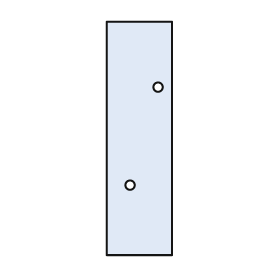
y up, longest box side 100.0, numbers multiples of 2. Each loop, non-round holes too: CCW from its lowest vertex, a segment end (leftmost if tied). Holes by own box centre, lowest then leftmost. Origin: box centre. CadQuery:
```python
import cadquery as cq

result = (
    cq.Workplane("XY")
    .moveTo(-14.0, -50.0)
    .lineTo(14.0, -50.0)
    .lineTo(14.0, 50.0)
    .lineTo(-14.0, 50.0)
    .close()
    .moveTo(-4.0, -20.0)
    .circle(2.0)
    .moveTo(8.0, 22.0)
    .circle(2.0)
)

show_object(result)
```